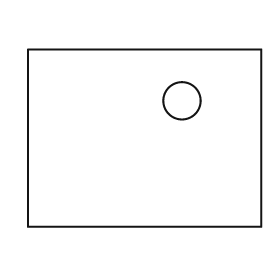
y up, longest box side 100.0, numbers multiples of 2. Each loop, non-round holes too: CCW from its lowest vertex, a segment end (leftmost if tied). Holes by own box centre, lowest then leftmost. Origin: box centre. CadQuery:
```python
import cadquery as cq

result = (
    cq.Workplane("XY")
    .moveTo(-50.0, -38.0)
    .lineTo(50.0, -38.0)
    .lineTo(50.0, 38.0)
    .lineTo(-50.0, 38.0)
    .close()
    .moveTo(16.0, 16.0)
    .circle(8.0)
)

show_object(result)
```